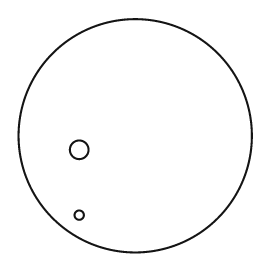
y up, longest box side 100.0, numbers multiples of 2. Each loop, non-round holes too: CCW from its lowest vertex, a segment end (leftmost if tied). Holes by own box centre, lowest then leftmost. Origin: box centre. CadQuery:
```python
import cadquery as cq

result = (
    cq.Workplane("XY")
    .moveTo(0.0, 0.0)
    .circle(50.0)
    .moveTo(-24.0, -34.0)
    .circle(2.0)
    .moveTo(-24.0, -6.0)
    .circle(4.0)
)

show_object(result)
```